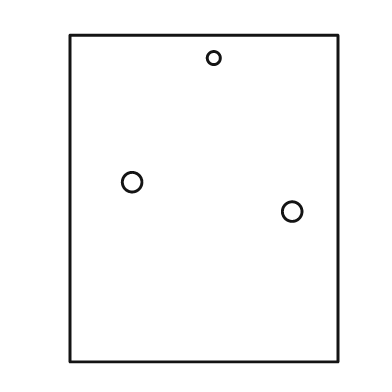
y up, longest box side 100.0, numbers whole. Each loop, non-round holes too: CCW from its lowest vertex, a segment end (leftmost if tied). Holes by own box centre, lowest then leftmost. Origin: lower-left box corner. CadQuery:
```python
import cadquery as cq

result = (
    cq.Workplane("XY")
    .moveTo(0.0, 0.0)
    .lineTo(82.0, 0.0)
    .lineTo(82.0, 100.0)
    .lineTo(0.0, 100.0)
    .close()
    .moveTo(68.0, 46.0)
    .circle(3.0)
    .moveTo(19.0, 55.0)
    .circle(3.0)
    .moveTo(44.0, 93.0)
    .circle(2.0)
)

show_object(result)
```